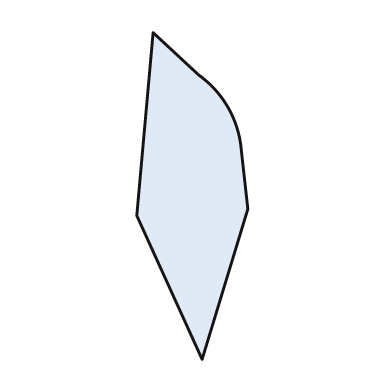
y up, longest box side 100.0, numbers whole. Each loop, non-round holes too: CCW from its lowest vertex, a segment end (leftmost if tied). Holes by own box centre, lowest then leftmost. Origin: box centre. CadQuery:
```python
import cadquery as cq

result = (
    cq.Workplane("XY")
    .moveTo(3.0, -50.0)
    .lineTo(17.0, -4.0)
    .lineTo(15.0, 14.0)
    .threePointArc((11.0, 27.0), (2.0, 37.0))
    .lineTo(-12.0, 50.0)
    .lineTo(-17.0, -6.0)
    .close()
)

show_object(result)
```